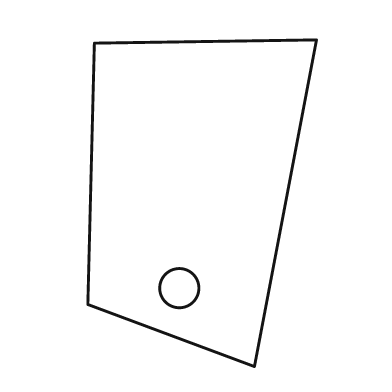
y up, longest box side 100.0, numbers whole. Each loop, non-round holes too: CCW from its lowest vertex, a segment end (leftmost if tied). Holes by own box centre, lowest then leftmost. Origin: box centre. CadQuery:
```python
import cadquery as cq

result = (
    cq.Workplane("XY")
    .moveTo(16.0, -50.0)
    .lineTo(35.0, 50.0)
    .lineTo(-33.0, 49.0)
    .lineTo(-35.0, -31.0)
    .close()
    .moveTo(-7.0, -26.0)
    .circle(6.0)
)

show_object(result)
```